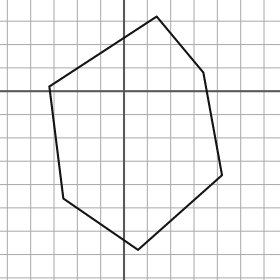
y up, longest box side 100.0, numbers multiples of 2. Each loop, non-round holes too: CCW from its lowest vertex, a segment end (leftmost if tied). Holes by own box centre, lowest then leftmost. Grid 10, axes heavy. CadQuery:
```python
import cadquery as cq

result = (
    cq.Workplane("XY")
    .moveTo(6.0, -68.0)
    .lineTo(42.0, -36.0)
    .lineTo(34.0, 8.0)
    .lineTo(14.0, 32.0)
    .lineTo(-32.0, 2.0)
    .lineTo(-26.0, -46.0)
    .close()
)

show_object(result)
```